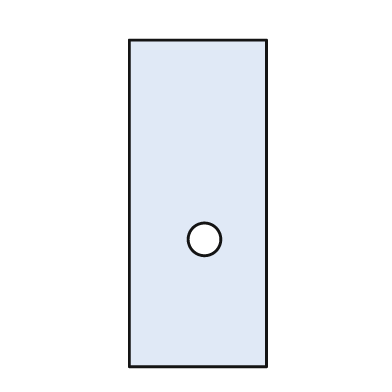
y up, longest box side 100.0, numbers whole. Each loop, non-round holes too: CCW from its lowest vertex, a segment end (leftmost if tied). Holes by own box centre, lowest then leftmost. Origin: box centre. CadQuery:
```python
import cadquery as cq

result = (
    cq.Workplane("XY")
    .moveTo(-21.0, -50.0)
    .lineTo(21.0, -50.0)
    .lineTo(21.0, 50.0)
    .lineTo(-21.0, 50.0)
    .close()
    .moveTo(2.0, -11.0)
    .circle(5.0)
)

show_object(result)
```